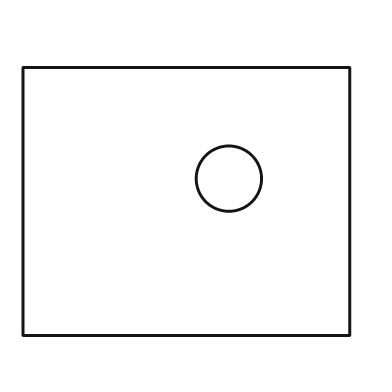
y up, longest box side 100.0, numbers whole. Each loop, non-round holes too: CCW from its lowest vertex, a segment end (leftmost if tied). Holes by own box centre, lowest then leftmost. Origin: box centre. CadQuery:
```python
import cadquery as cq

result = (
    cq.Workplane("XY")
    .moveTo(-50.0, -41.0)
    .lineTo(50.0, -41.0)
    .lineTo(50.0, 41.0)
    .lineTo(-50.0, 41.0)
    .close()
    .moveTo(13.0, 7.0)
    .circle(10.0)
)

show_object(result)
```